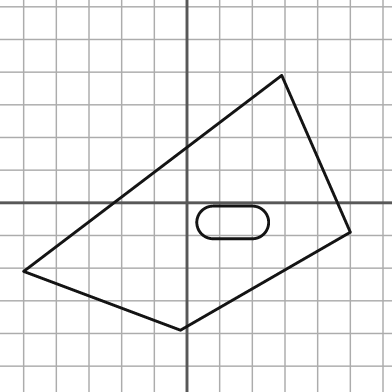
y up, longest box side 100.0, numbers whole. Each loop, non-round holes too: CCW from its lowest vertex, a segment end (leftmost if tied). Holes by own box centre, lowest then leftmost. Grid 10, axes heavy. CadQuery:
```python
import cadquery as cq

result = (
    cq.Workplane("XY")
    .moveTo(-2.0, -39.0)
    .lineTo(50.0, -9.0)
    .lineTo(29.0, 39.0)
    .lineTo(-50.0, -21.0)
    .close()
    .moveTo(8.0, -11.0)
    .lineTo(20.0, -11.0)
    .threePointArc((25.0, -6.0), (20.0, -1.0))
    .lineTo(8.0, -1.0)
    .threePointArc((3.0, -6.0), (8.0, -11.0))
    .close()
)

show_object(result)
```